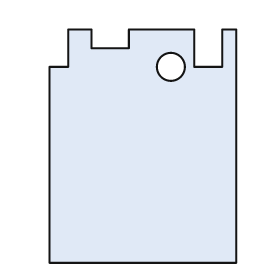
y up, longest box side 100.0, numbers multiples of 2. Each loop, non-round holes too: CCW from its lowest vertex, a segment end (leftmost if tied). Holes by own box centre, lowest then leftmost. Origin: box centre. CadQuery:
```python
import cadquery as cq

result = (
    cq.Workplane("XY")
    .moveTo(-40.0, -50.0)
    .lineTo(40.0, -50.0)
    .lineTo(40.0, 50.0)
    .lineTo(34.0, 50.0)
    .lineTo(34.0, 34.0)
    .lineTo(22.0, 34.0)
    .lineTo(22.0, 50.0)
    .lineTo(-6.0, 50.0)
    .lineTo(-6.0, 42.0)
    .lineTo(-22.0, 42.0)
    .lineTo(-22.0, 50.0)
    .lineTo(-32.0, 50.0)
    .lineTo(-32.0, 34.0)
    .lineTo(-40.0, 34.0)
    .close()
    .moveTo(12.0, 34.0)
    .circle(6.0)
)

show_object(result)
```